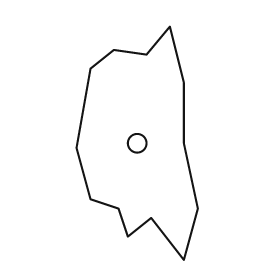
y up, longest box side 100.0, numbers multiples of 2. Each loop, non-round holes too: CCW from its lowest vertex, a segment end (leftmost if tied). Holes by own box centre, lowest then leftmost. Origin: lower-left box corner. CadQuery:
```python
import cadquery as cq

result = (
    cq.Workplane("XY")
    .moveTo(46.0, 0.0)
    .lineTo(52.0, 22.0)
    .lineTo(46.0, 50.0)
    .lineTo(46.0, 76.0)
    .lineTo(40.0, 100.0)
    .lineTo(30.0, 88.0)
    .lineTo(16.0, 90.0)
    .lineTo(6.0, 82.0)
    .lineTo(0.0, 48.0)
    .lineTo(6.0, 26.0)
    .lineTo(18.0, 22.0)
    .lineTo(22.0, 10.0)
    .lineTo(32.0, 18.0)
    .close()
    .moveTo(26.0, 50.0)
    .circle(4.0)
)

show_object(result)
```